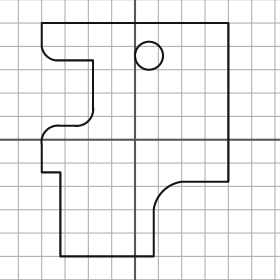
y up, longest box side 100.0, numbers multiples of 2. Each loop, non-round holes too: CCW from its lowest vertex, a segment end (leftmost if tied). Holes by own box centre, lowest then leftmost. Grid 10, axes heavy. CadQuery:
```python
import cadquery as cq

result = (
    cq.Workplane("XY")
    .moveTo(-32.0, -50.0)
    .lineTo(8.0, -50.0)
    .lineTo(8.0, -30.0)
    .threePointArc((12.0, -22.0), (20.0, -18.0))
    .lineTo(40.0, -18.0)
    .lineTo(40.0, 50.0)
    .lineTo(-40.0, 50.0)
    .lineTo(-40.0, 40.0)
    .threePointArc((-38.0, 36.0), (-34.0, 34.0))
    .lineTo(-18.0, 34.0)
    .lineTo(-18.0, 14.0)
    .threePointArc((-20.0, 8.0), (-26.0, 6.0))
    .lineTo(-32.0, 6.0)
    .threePointArc((-38.0, 4.0), (-40.0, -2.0))
    .lineTo(-40.0, -14.0)
    .lineTo(-32.0, -14.0)
    .close()
    .moveTo(6.0, 36.0)
    .circle(6.0)
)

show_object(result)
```